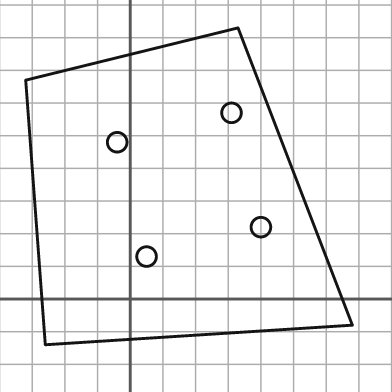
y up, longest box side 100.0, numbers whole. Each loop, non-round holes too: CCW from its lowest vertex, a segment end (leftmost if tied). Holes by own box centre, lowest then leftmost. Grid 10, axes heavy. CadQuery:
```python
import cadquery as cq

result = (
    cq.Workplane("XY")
    .moveTo(-26.0, -14.0)
    .lineTo(68.0, -8.0)
    .lineTo(33.0, 83.0)
    .lineTo(-32.0, 67.0)
    .close()
    .moveTo(5.0, 13.0)
    .circle(3.0)
    .moveTo(40.0, 22.0)
    .circle(3.0)
    .moveTo(-4.0, 48.0)
    .circle(3.0)
    .moveTo(31.0, 57.0)
    .circle(3.0)
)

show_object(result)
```